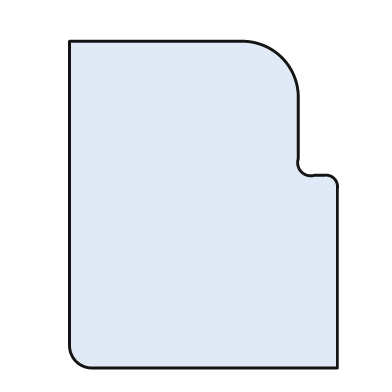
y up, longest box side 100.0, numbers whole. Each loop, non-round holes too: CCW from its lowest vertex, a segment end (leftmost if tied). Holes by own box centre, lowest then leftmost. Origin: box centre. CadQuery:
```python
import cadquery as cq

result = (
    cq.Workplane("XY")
    .moveTo(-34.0, -50.0)
    .lineTo(41.0, -50.0)
    .lineTo(41.0, 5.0)
    .threePointArc((40.0, 8.0), (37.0, 9.0))
    .lineTo(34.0, 9.0)
    .threePointArc((30.0, 10.0), (29.0, 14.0))
    .lineTo(29.0, 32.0)
    .threePointArc((24.0, 45.0), (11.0, 50.0))
    .lineTo(-41.0, 50.0)
    .lineTo(-41.0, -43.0)
    .threePointArc((-39.0, -48.0), (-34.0, -50.0))
    .close()
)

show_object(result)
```